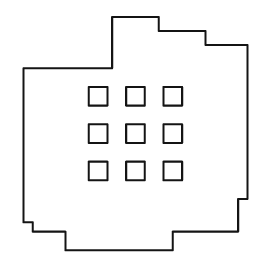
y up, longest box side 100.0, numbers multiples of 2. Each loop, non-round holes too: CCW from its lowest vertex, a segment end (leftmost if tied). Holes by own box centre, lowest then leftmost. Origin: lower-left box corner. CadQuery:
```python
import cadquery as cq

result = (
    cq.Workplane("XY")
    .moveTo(18.0, 0.0)
    .lineTo(64.0, 0.0)
    .lineTo(64.0, 8.0)
    .lineTo(92.0, 8.0)
    .lineTo(92.0, 22.0)
    .lineTo(96.0, 22.0)
    .lineTo(96.0, 88.0)
    .lineTo(78.0, 88.0)
    .lineTo(78.0, 94.0)
    .lineTo(58.0, 94.0)
    .lineTo(58.0, 100.0)
    .lineTo(38.0, 100.0)
    .lineTo(38.0, 78.0)
    .lineTo(0.0, 78.0)
    .lineTo(0.0, 12.0)
    .lineTo(4.0, 12.0)
    .lineTo(4.0, 8.0)
    .lineTo(18.0, 8.0)
    .close()
    .moveTo(28.0, 30.0)
    .lineTo(36.0, 30.0)
    .lineTo(36.0, 38.0)
    .lineTo(28.0, 38.0)
    .close()
    .moveTo(44.0, 30.0)
    .lineTo(52.0, 30.0)
    .lineTo(52.0, 38.0)
    .lineTo(44.0, 38.0)
    .close()
    .moveTo(60.0, 30.0)
    .lineTo(68.0, 30.0)
    .lineTo(68.0, 38.0)
    .lineTo(60.0, 38.0)
    .close()
    .moveTo(28.0, 46.0)
    .lineTo(36.0, 46.0)
    .lineTo(36.0, 54.0)
    .lineTo(28.0, 54.0)
    .close()
    .moveTo(44.0, 46.0)
    .lineTo(52.0, 46.0)
    .lineTo(52.0, 54.0)
    .lineTo(44.0, 54.0)
    .close()
    .moveTo(60.0, 46.0)
    .lineTo(68.0, 46.0)
    .lineTo(68.0, 54.0)
    .lineTo(60.0, 54.0)
    .close()
    .moveTo(28.0, 62.0)
    .lineTo(36.0, 62.0)
    .lineTo(36.0, 70.0)
    .lineTo(28.0, 70.0)
    .close()
    .moveTo(44.0, 62.0)
    .lineTo(52.0, 62.0)
    .lineTo(52.0, 70.0)
    .lineTo(44.0, 70.0)
    .close()
    .moveTo(60.0, 62.0)
    .lineTo(68.0, 62.0)
    .lineTo(68.0, 70.0)
    .lineTo(60.0, 70.0)
    .close()
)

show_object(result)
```